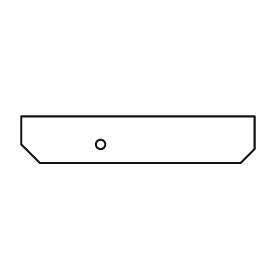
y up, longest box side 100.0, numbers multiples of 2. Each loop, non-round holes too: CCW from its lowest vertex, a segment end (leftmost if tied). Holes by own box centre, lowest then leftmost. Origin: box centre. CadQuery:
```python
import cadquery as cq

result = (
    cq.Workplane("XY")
    .moveTo(-42.0, -10.0)
    .lineTo(44.0, -10.0)
    .lineTo(50.0, -4.0)
    .lineTo(50.0, 10.0)
    .lineTo(-50.0, 10.0)
    .lineTo(-50.0, -2.0)
    .close()
    .moveTo(-16.0, -2.0)
    .circle(2.0)
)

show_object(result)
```